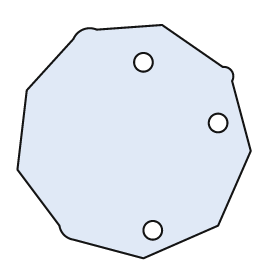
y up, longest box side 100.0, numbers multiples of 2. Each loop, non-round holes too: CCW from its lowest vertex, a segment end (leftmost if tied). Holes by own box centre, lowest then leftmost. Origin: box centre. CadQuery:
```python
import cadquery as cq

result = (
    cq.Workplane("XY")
    .moveTo(4.0, -50.0)
    .lineTo(36.0, -36.0)
    .lineTo(50.0, -4.0)
    .lineTo(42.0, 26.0)
    .threePointArc((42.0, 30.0), (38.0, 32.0))
    .lineTo(12.0, 50.0)
    .lineTo(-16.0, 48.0)
    .threePointArc((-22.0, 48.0), (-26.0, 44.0))
    .lineTo(-46.0, 22.0)
    .lineTo(-50.0, -12.0)
    .lineTo(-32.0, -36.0)
    .threePointArc((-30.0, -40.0), (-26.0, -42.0))
    .close()
    .moveTo(8.0, -38.0)
    .circle(4.0)
    .moveTo(36.0, 8.0)
    .circle(4.0)
    .moveTo(4.0, 34.0)
    .circle(4.0)
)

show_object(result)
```